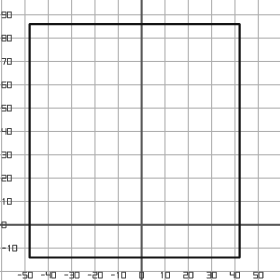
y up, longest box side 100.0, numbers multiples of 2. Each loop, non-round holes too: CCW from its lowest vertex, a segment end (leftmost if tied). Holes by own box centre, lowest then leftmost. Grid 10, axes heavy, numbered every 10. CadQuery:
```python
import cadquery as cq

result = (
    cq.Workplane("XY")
    .moveTo(-48.0, -14.0)
    .lineTo(42.0, -14.0)
    .lineTo(42.0, 86.0)
    .lineTo(-48.0, 86.0)
    .close()
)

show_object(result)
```